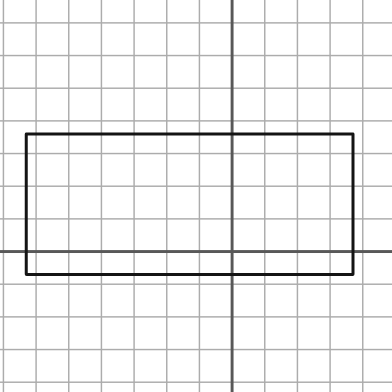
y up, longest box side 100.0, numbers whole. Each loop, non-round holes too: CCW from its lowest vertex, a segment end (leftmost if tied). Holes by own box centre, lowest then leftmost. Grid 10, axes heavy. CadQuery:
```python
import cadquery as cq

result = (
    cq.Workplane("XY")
    .moveTo(-63.0, -7.0)
    .lineTo(37.0, -7.0)
    .lineTo(37.0, 36.0)
    .lineTo(-63.0, 36.0)
    .close()
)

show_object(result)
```